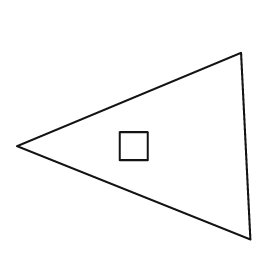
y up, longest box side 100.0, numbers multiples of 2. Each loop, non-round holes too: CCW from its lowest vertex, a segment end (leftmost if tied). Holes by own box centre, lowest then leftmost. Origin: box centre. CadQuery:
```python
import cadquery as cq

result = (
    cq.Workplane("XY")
    .moveTo(50.0, -40.0)
    .lineTo(46.0, 40.0)
    .lineTo(-50.0, 0.0)
    .close()
    .moveTo(-6.0, -6.0)
    .lineTo(6.0, -6.0)
    .lineTo(6.0, 6.0)
    .lineTo(-6.0, 6.0)
    .close()
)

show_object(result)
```